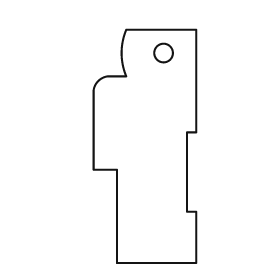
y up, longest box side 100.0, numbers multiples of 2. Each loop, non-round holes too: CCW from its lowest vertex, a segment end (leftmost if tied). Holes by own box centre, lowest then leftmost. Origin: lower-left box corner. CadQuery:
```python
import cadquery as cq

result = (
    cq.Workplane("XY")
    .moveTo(10.0, 0.0)
    .lineTo(44.0, 0.0)
    .lineTo(44.0, 22.0)
    .lineTo(40.0, 22.0)
    .lineTo(40.0, 56.0)
    .lineTo(44.0, 56.0)
    .lineTo(44.0, 100.0)
    .lineTo(14.0, 100.0)
    .threePointArc((12.0, 90.0), (14.0, 80.0))
    .lineTo(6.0, 80.0)
    .threePointArc((2.0, 78.0), (0.0, 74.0))
    .lineTo(0.0, 40.0)
    .lineTo(10.0, 40.0)
    .close()
    .moveTo(30.0, 90.0)
    .circle(4.0)
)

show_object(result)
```